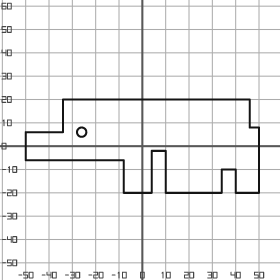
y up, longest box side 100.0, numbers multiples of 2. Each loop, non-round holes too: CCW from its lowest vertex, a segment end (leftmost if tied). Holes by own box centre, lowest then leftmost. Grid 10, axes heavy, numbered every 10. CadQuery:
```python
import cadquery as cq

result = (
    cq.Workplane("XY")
    .moveTo(-8.0, -20.0)
    .lineTo(4.0, -20.0)
    .lineTo(4.0, -2.0)
    .lineTo(10.0, -2.0)
    .lineTo(10.0, -20.0)
    .lineTo(34.0, -20.0)
    .lineTo(34.0, -10.0)
    .lineTo(40.0, -10.0)
    .lineTo(40.0, -20.0)
    .lineTo(50.0, -20.0)
    .lineTo(50.0, 8.0)
    .lineTo(46.0, 8.0)
    .lineTo(46.0, 20.0)
    .lineTo(-34.0, 20.0)
    .lineTo(-34.0, 6.0)
    .lineTo(-50.0, 6.0)
    .lineTo(-50.0, -6.0)
    .lineTo(-8.0, -6.0)
    .close()
    .moveTo(-26.0, 6.0)
    .circle(2.0)
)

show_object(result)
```